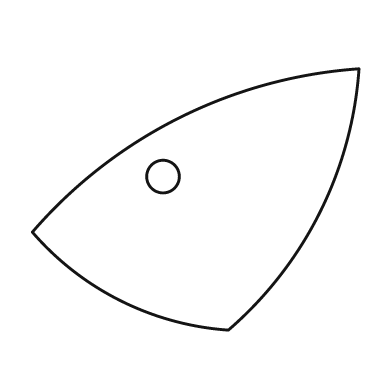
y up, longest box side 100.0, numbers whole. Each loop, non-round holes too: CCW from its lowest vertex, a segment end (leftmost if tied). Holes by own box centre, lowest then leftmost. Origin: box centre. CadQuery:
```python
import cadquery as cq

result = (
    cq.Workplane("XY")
    .moveTo(10.0, -40.0)
    .threePointArc((38.0, -4.0), (50.0, 40.0))
    .threePointArc((-5.0, 25.0), (-50.0, -10.0))
    .threePointArc((-23.0, -31.0), (10.0, -40.0))
    .close()
    .moveTo(-10.0, 7.0)
    .circle(5.0)
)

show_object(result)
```